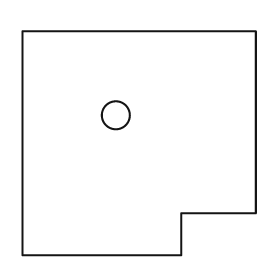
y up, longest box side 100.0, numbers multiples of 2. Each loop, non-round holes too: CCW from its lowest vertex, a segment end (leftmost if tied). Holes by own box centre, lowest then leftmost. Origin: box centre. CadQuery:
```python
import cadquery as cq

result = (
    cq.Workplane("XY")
    .moveTo(-50.0, -48.0)
    .lineTo(18.0, -48.0)
    .lineTo(18.0, -30.0)
    .lineTo(50.0, -30.0)
    .lineTo(50.0, 48.0)
    .lineTo(-50.0, 48.0)
    .close()
    .moveTo(-10.0, 12.0)
    .circle(6.0)
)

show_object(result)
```